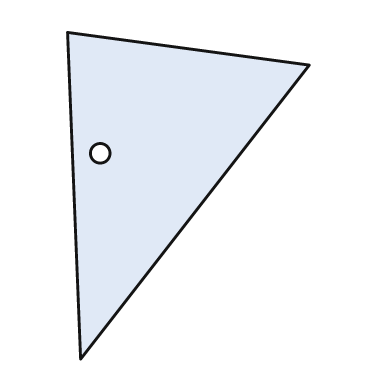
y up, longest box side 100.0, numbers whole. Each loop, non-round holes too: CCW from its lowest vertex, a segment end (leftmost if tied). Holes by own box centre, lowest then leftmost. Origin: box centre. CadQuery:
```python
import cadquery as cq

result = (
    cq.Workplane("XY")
    .moveTo(-33.0, -50.0)
    .lineTo(37.0, 40.0)
    .lineTo(-37.0, 50.0)
    .close()
    .moveTo(-27.0, 13.0)
    .circle(3.0)
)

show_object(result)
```